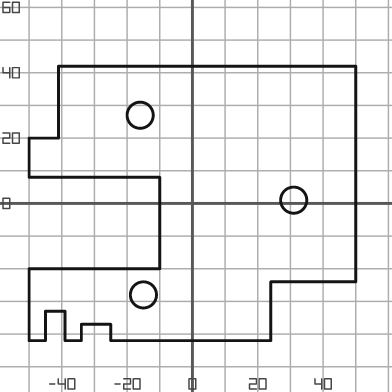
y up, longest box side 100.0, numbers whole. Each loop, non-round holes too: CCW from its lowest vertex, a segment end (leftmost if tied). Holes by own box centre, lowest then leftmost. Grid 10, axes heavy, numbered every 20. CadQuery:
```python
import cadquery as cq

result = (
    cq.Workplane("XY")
    .moveTo(-50.0, -42.0)
    .lineTo(-45.0, -42.0)
    .lineTo(-45.0, -33.0)
    .lineTo(-39.0, -33.0)
    .lineTo(-39.0, -42.0)
    .lineTo(-34.0, -42.0)
    .lineTo(-34.0, -37.0)
    .lineTo(-25.0, -37.0)
    .lineTo(-25.0, -42.0)
    .lineTo(24.0, -42.0)
    .lineTo(24.0, -24.0)
    .lineTo(50.0, -24.0)
    .lineTo(50.0, 42.0)
    .lineTo(-41.0, 42.0)
    .lineTo(-41.0, 20.0)
    .lineTo(-50.0, 20.0)
    .lineTo(-50.0, 8.0)
    .lineTo(-10.0, 8.0)
    .lineTo(-10.0, -20.0)
    .lineTo(-50.0, -20.0)
    .close()
    .moveTo(-15.0, -28.0)
    .circle(4.0)
    .moveTo(31.0, 1.0)
    .circle(4.0)
    .moveTo(-16.0, 27.0)
    .circle(4.0)
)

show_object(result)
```